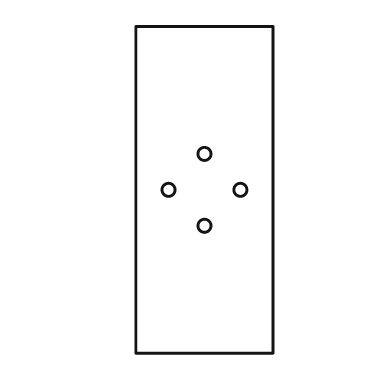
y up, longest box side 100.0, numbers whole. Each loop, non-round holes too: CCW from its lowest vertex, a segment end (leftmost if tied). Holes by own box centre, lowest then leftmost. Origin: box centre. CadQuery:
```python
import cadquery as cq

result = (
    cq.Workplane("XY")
    .moveTo(-21.0, -50.0)
    .lineTo(21.0, -50.0)
    .lineTo(21.0, 50.0)
    .lineTo(-21.0, 50.0)
    .close()
    .moveTo(0.0, -11.0)
    .circle(2.0)
    .moveTo(-11.0, 0.0)
    .circle(2.0)
    .moveTo(11.0, 0.0)
    .circle(2.0)
    .moveTo(0.0, 11.0)
    .circle(2.0)
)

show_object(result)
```